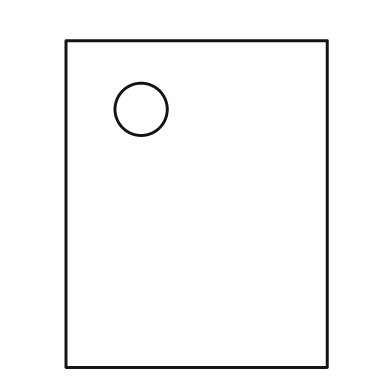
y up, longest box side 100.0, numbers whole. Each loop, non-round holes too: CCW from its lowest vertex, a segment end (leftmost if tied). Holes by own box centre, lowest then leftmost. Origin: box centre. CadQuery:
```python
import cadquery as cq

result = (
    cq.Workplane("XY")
    .moveTo(-40.0, -50.0)
    .lineTo(40.0, -50.0)
    .lineTo(40.0, 50.0)
    .lineTo(-40.0, 50.0)
    .close()
    .moveTo(-17.0, 29.0)
    .circle(8.0)
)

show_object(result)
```